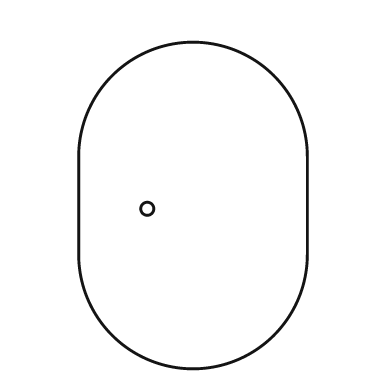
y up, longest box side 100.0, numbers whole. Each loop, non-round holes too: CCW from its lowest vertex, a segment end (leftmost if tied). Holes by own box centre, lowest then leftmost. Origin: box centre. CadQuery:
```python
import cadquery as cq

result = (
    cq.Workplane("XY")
    .moveTo(-35.0, -15.0)
    .threePointArc((0.0, -50.0), (35.0, -15.0))
    .lineTo(35.0, 15.0)
    .threePointArc((0.0, 50.0), (-35.0, 15.0))
    .close()
    .moveTo(-14.0, -1.0)
    .circle(2.0)
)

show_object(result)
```